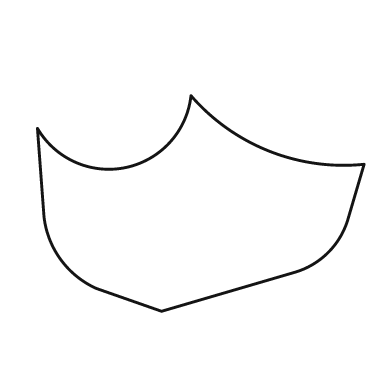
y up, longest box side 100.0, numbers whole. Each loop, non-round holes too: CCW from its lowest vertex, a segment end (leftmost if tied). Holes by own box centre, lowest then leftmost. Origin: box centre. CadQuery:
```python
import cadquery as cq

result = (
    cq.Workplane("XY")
    .moveTo(-12.0, -33.0)
    .lineTo(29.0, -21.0)
    .threePointArc((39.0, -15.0), (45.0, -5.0))
    .lineTo(50.0, 12.0)
    .threePointArc((21.0, 16.0), (-3.0, 33.0))
    .threePointArc((-23.0, 11.0), (-50.0, 23.0))
    .lineTo(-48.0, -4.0)
    .threePointArc((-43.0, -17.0), (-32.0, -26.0))
    .close()
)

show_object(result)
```